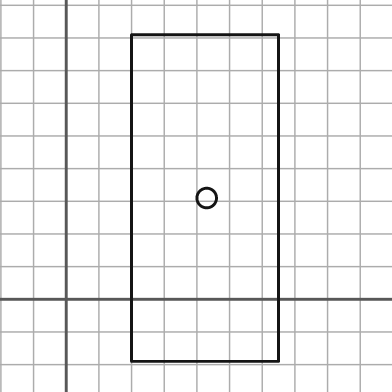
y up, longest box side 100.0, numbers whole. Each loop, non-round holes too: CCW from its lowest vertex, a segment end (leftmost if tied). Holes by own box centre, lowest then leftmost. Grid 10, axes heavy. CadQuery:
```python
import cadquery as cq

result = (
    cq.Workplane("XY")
    .moveTo(20.0, -19.0)
    .lineTo(65.0, -19.0)
    .lineTo(65.0, 81.0)
    .lineTo(20.0, 81.0)
    .close()
    .moveTo(43.0, 31.0)
    .circle(3.0)
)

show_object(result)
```